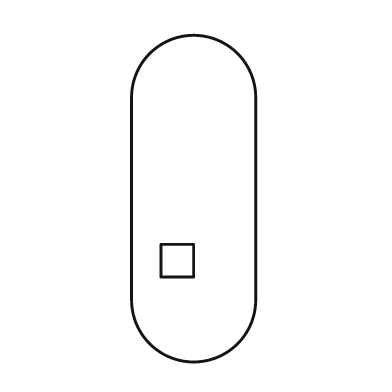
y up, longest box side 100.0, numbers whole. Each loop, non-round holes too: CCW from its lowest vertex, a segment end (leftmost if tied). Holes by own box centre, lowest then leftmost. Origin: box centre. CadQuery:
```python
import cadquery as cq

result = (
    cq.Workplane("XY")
    .moveTo(-19.0, -31.0)
    .threePointArc((0.0, -50.0), (19.0, -31.0))
    .lineTo(19.0, 31.0)
    .threePointArc((0.0, 50.0), (-19.0, 31.0))
    .close()
    .moveTo(-10.0, -24.0)
    .lineTo(0.0, -24.0)
    .lineTo(0.0, -14.0)
    .lineTo(-10.0, -14.0)
    .close()
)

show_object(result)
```